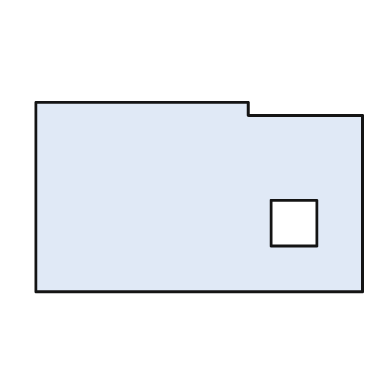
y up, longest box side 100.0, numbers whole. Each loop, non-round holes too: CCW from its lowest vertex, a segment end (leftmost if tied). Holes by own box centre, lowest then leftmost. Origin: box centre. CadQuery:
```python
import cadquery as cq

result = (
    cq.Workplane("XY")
    .moveTo(-50.0, -29.0)
    .lineTo(50.0, -29.0)
    .lineTo(50.0, 25.0)
    .lineTo(15.0, 25.0)
    .lineTo(15.0, 29.0)
    .lineTo(-50.0, 29.0)
    .close()
    .moveTo(22.0, -15.0)
    .lineTo(36.0, -15.0)
    .lineTo(36.0, -1.0)
    .lineTo(22.0, -1.0)
    .close()
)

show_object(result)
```